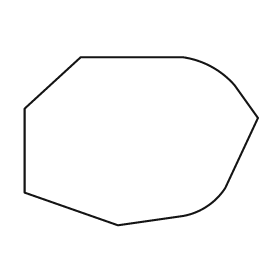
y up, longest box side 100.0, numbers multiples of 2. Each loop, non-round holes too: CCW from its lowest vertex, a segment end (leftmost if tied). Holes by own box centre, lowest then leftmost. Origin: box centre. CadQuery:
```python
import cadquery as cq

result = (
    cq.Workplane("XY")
    .moveTo(-10.0, -36.0)
    .lineTo(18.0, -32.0)
    .threePointArc((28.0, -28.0), (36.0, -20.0))
    .lineTo(50.0, 10.0)
    .lineTo(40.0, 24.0)
    .threePointArc((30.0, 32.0), (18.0, 36.0))
    .lineTo(-26.0, 36.0)
    .lineTo(-50.0, 14.0)
    .lineTo(-50.0, -22.0)
    .close()
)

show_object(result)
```